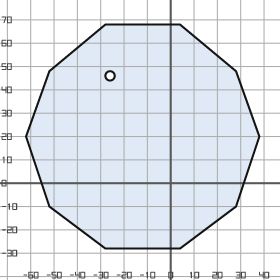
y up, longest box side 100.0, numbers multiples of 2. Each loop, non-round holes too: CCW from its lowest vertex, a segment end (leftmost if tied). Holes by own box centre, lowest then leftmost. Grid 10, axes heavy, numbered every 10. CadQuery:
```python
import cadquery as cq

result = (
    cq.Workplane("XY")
    .moveTo(-28.0, -28.0)
    .lineTo(4.0, -28.0)
    .lineTo(28.0, -10.0)
    .lineTo(38.0, 20.0)
    .lineTo(28.0, 48.0)
    .lineTo(4.0, 68.0)
    .lineTo(-28.0, 68.0)
    .lineTo(-52.0, 48.0)
    .lineTo(-62.0, 20.0)
    .lineTo(-52.0, -10.0)
    .close()
    .moveTo(-26.0, 46.0)
    .circle(2.0)
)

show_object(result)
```